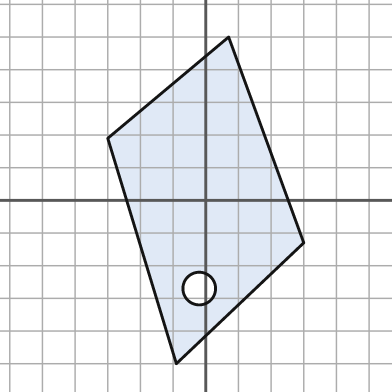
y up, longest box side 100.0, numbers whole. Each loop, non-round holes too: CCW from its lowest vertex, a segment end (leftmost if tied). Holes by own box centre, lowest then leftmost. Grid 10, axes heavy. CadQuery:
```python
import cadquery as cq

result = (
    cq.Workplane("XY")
    .moveTo(-9.0, -50.0)
    .lineTo(30.0, -13.0)
    .lineTo(7.0, 50.0)
    .lineTo(-30.0, 19.0)
    .close()
    .moveTo(-2.0, -27.0)
    .circle(5.0)
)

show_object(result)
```